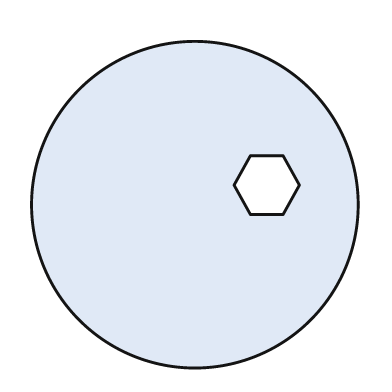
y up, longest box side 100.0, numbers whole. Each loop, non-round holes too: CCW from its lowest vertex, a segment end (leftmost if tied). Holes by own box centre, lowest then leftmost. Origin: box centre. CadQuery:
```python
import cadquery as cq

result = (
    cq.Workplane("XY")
    .moveTo(0.0, 0.0)
    .circle(50.0)
    .moveTo(17.0, -3.0)
    .lineTo(27.0, -3.0)
    .lineTo(32.0, 6.0)
    .lineTo(27.0, 15.0)
    .lineTo(17.0, 15.0)
    .lineTo(12.0, 6.0)
    .close()
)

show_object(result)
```